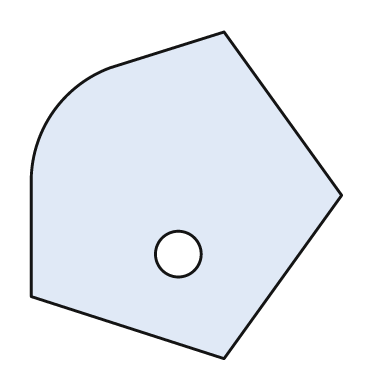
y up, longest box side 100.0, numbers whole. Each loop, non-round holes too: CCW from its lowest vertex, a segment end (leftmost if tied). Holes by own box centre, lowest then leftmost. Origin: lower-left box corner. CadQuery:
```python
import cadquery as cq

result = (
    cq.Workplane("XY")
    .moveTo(59.0, 0.0)
    .lineTo(95.0, 50.0)
    .lineTo(59.0, 100.0)
    .lineTo(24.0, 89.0)
    .threePointArc((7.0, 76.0), (0.0, 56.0))
    .lineTo(0.0, 19.0)
    .close()
    .moveTo(45.0, 32.0)
    .circle(7.0)
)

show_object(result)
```